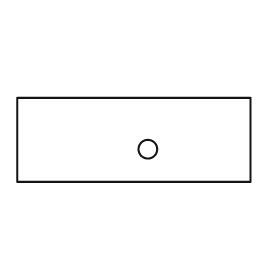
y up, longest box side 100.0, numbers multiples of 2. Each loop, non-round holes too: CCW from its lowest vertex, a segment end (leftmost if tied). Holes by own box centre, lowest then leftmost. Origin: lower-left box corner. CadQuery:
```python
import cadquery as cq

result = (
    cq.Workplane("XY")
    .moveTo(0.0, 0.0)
    .lineTo(100.0, 0.0)
    .lineTo(100.0, 36.0)
    .lineTo(0.0, 36.0)
    .close()
    .moveTo(56.0, 14.0)
    .circle(4.0)
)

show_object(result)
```